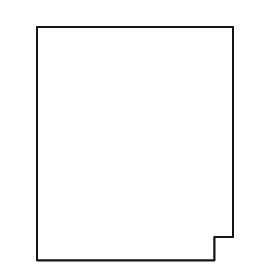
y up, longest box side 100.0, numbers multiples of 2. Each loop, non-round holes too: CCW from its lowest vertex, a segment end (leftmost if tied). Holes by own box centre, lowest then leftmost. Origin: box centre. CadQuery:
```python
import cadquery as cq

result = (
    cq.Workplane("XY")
    .moveTo(-42.0, -50.0)
    .lineTo(34.0, -50.0)
    .lineTo(34.0, -40.0)
    .lineTo(42.0, -40.0)
    .lineTo(42.0, 50.0)
    .lineTo(-42.0, 50.0)
    .close()
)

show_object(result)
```